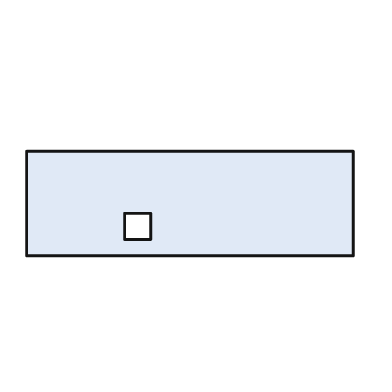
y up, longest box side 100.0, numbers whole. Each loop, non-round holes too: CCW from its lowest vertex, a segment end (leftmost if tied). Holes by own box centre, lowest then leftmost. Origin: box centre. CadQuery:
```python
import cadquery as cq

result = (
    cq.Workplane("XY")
    .moveTo(-50.0, -16.0)
    .lineTo(50.0, -16.0)
    .lineTo(50.0, 16.0)
    .lineTo(-50.0, 16.0)
    .close()
    .moveTo(-20.0, -11.0)
    .lineTo(-12.0, -11.0)
    .lineTo(-12.0, -3.0)
    .lineTo(-20.0, -3.0)
    .close()
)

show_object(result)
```